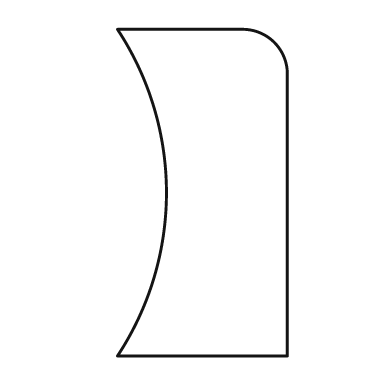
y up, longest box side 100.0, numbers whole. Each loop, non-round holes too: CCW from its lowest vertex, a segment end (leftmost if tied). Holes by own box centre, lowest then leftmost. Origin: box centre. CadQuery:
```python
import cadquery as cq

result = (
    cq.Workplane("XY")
    .moveTo(-26.0, -50.0)
    .lineTo(26.0, -50.0)
    .lineTo(26.0, 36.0)
    .threePointArc((22.0, 46.0), (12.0, 50.0))
    .lineTo(-26.0, 50.0)
    .threePointArc((-11.0, 0.0), (-26.0, -50.0))
    .close()
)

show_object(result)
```